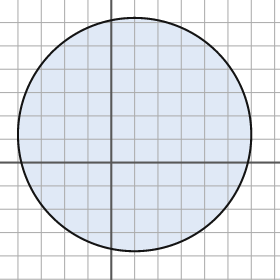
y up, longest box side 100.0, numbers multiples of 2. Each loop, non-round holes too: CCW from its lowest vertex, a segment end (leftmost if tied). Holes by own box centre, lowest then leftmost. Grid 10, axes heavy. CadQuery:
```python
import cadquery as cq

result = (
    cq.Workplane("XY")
    .moveTo(10.0, 12.0)
    .circle(50.0)
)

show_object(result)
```